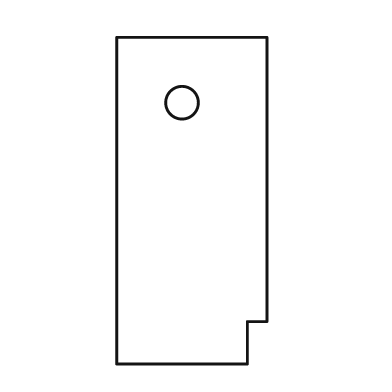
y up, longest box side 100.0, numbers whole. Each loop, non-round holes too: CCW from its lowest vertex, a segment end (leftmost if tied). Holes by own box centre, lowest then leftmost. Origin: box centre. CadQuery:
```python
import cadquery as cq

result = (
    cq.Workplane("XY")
    .moveTo(-23.0, -50.0)
    .lineTo(17.0, -50.0)
    .lineTo(17.0, -37.0)
    .lineTo(23.0, -37.0)
    .lineTo(23.0, 50.0)
    .lineTo(-23.0, 50.0)
    .close()
    .moveTo(-3.0, 30.0)
    .circle(5.0)
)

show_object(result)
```